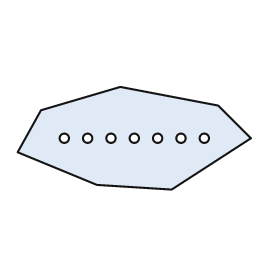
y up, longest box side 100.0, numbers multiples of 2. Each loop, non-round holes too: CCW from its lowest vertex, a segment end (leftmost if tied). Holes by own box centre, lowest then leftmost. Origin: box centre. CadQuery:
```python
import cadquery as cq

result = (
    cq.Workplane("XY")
    .moveTo(16.0, -22.0)
    .lineTo(50.0, 0.0)
    .lineTo(36.0, 14.0)
    .lineTo(-6.0, 22.0)
    .lineTo(-40.0, 12.0)
    .lineTo(-50.0, -6.0)
    .lineTo(-16.0, -20.0)
    .close()
    .moveTo(-30.0, 0.0)
    .circle(2.0)
    .moveTo(-20.0, 0.0)
    .circle(2.0)
    .moveTo(-10.0, 0.0)
    .circle(2.0)
    .moveTo(0.0, 0.0)
    .circle(2.0)
    .moveTo(10.0, 0.0)
    .circle(2.0)
    .moveTo(20.0, 0.0)
    .circle(2.0)
    .moveTo(30.0, 0.0)
    .circle(2.0)
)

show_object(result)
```